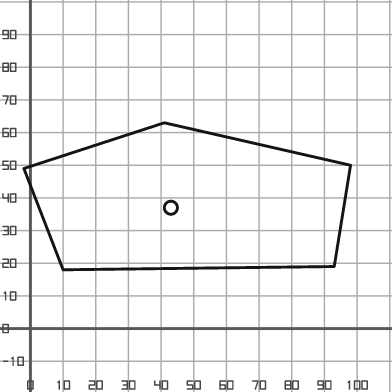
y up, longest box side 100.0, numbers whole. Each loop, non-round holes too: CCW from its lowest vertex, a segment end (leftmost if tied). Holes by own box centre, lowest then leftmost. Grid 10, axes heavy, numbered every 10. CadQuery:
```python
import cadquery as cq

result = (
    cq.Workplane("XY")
    .moveTo(10.0, 18.0)
    .lineTo(93.0, 19.0)
    .lineTo(98.0, 50.0)
    .lineTo(41.0, 63.0)
    .lineTo(-2.0, 49.0)
    .close()
    .moveTo(43.0, 37.0)
    .circle(2.0)
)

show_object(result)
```